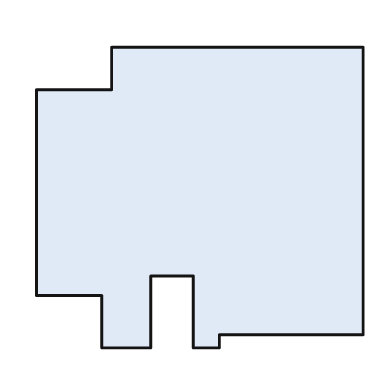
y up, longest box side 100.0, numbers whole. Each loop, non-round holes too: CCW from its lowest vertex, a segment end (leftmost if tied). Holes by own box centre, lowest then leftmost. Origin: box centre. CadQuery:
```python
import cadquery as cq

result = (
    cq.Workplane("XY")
    .moveTo(-30.0, -46.0)
    .lineTo(-15.0, -46.0)
    .lineTo(-15.0, -24.0)
    .lineTo(-2.0, -24.0)
    .lineTo(-2.0, -46.0)
    .lineTo(6.0, -46.0)
    .lineTo(6.0, -42.0)
    .lineTo(50.0, -42.0)
    .lineTo(50.0, 46.0)
    .lineTo(-27.0, 46.0)
    .lineTo(-27.0, 33.0)
    .lineTo(-50.0, 33.0)
    .lineTo(-50.0, -30.0)
    .lineTo(-30.0, -30.0)
    .close()
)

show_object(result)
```